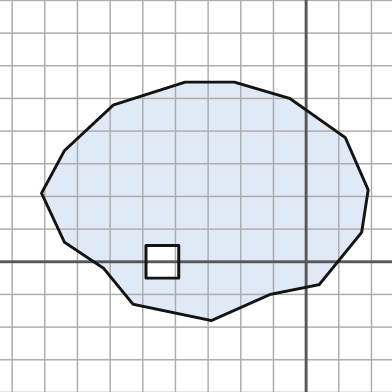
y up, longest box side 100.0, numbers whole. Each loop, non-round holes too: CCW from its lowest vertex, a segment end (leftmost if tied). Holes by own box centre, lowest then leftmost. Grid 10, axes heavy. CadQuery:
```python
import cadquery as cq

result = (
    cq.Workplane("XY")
    .moveTo(-29.0, -18.0)
    .lineTo(-11.0, -10.0)
    .lineTo(4.0, -7.0)
    .lineTo(17.0, 9.0)
    .lineTo(19.0, 22.0)
    .lineTo(12.0, 38.0)
    .lineTo(-5.0, 50.0)
    .lineTo(-22.0, 55.0)
    .lineTo(-37.0, 55.0)
    .lineTo(-59.0, 48.0)
    .lineTo(-74.0, 34.0)
    .lineTo(-81.0, 21.0)
    .lineTo(-74.0, 6.0)
    .lineTo(-62.0, -2.0)
    .lineTo(-53.0, -13.0)
    .close()
    .moveTo(-49.0, -5.0)
    .lineTo(-39.0, -5.0)
    .lineTo(-39.0, 5.0)
    .lineTo(-49.0, 5.0)
    .close()
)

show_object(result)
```